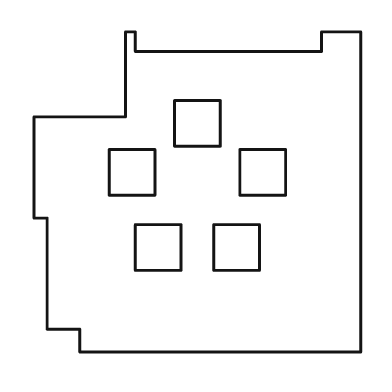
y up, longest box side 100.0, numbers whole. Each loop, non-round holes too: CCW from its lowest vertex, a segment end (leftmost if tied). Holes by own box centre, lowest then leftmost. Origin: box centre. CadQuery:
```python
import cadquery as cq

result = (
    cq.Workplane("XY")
    .moveTo(-36.0, -49.0)
    .lineTo(50.0, -49.0)
    .lineTo(50.0, 49.0)
    .lineTo(38.0, 49.0)
    .lineTo(38.0, 43.0)
    .lineTo(-19.0, 43.0)
    .lineTo(-19.0, 49.0)
    .lineTo(-22.0, 49.0)
    .lineTo(-22.0, 23.0)
    .lineTo(-50.0, 23.0)
    .lineTo(-50.0, -8.0)
    .lineTo(-46.0, -8.0)
    .lineTo(-46.0, -42.0)
    .lineTo(-36.0, -42.0)
    .close()
    .moveTo(-19.0, -24.0)
    .lineTo(-5.0, -24.0)
    .lineTo(-5.0, -10.0)
    .lineTo(-19.0, -10.0)
    .close()
    .moveTo(5.0, -24.0)
    .lineTo(19.0, -24.0)
    .lineTo(19.0, -10.0)
    .lineTo(5.0, -10.0)
    .close()
    .moveTo(-27.0, -1.0)
    .lineTo(-13.0, -1.0)
    .lineTo(-13.0, 13.0)
    .lineTo(-27.0, 13.0)
    .close()
    .moveTo(13.0, -1.0)
    .lineTo(27.0, -1.0)
    .lineTo(27.0, 13.0)
    .lineTo(13.0, 13.0)
    .close()
    .moveTo(-7.0, 14.0)
    .lineTo(7.0, 14.0)
    .lineTo(7.0, 28.0)
    .lineTo(-7.0, 28.0)
    .close()
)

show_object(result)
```